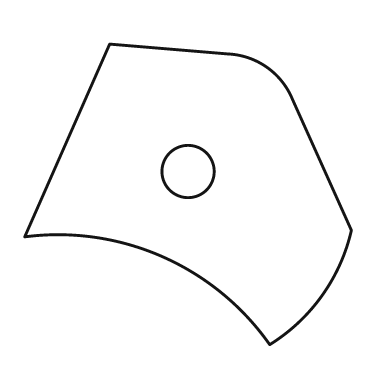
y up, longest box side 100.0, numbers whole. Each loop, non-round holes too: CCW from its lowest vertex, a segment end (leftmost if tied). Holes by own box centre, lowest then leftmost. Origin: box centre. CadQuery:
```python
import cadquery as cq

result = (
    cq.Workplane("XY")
    .moveTo(25.0, -46.0)
    .threePointArc((41.0, -31.0), (50.0, -11.0))
    .lineTo(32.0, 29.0)
    .threePointArc((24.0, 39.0), (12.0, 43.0))
    .lineTo(-24.0, 46.0)
    .lineTo(-50.0, -13.0)
    .threePointArc((-8.0, -19.0), (25.0, -46.0))
    .close()
    .moveTo(0.0, 7.0)
    .circle(8.0)
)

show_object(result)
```